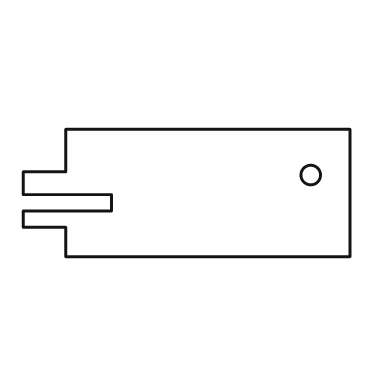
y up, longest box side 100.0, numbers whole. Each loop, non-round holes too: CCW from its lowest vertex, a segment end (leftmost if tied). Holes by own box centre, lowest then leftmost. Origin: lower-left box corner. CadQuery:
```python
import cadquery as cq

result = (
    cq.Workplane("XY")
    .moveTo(13.0, 0.0)
    .lineTo(100.0, 0.0)
    .lineTo(100.0, 39.0)
    .lineTo(13.0, 39.0)
    .lineTo(13.0, 26.0)
    .lineTo(0.0, 26.0)
    .lineTo(0.0, 19.0)
    .lineTo(27.0, 19.0)
    .lineTo(27.0, 14.0)
    .lineTo(0.0, 14.0)
    .lineTo(0.0, 9.0)
    .lineTo(13.0, 9.0)
    .close()
    .moveTo(88.0, 25.0)
    .circle(3.0)
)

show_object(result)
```